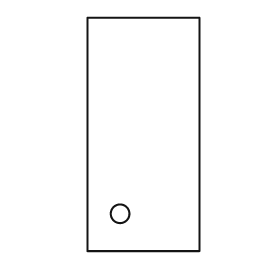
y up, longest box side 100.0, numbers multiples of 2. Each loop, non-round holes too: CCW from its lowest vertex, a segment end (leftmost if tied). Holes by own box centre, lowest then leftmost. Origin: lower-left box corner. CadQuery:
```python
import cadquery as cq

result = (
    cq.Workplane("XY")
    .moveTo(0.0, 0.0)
    .lineTo(48.0, 0.0)
    .lineTo(48.0, 100.0)
    .lineTo(0.0, 100.0)
    .close()
    .moveTo(14.0, 16.0)
    .circle(4.0)
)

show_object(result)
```